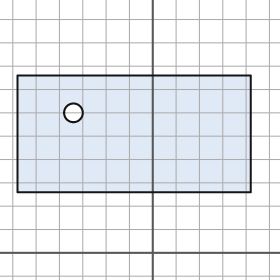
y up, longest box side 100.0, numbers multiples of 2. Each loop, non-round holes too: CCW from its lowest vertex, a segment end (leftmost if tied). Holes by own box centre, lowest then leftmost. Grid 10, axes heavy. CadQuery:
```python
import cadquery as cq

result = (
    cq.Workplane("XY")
    .moveTo(-58.0, 26.0)
    .lineTo(42.0, 26.0)
    .lineTo(42.0, 76.0)
    .lineTo(-58.0, 76.0)
    .close()
    .moveTo(-34.0, 60.0)
    .circle(4.0)
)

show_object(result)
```